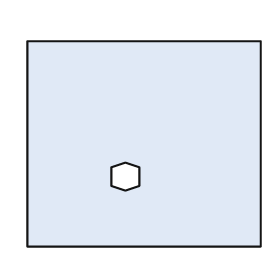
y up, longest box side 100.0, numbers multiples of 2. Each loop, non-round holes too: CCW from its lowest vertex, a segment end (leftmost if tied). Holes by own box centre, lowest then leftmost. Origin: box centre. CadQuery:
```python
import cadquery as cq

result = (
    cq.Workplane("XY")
    .moveTo(-50.0, -44.0)
    .lineTo(50.0, -44.0)
    .lineTo(50.0, 44.0)
    .lineTo(-50.0, 44.0)
    .close()
    .moveTo(-8.0, -20.0)
    .lineTo(-2.0, -18.0)
    .lineTo(-2.0, -10.0)
    .lineTo(-8.0, -8.0)
    .lineTo(-14.0, -10.0)
    .lineTo(-14.0, -18.0)
    .close()
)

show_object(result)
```